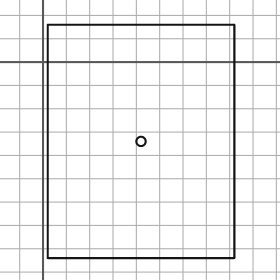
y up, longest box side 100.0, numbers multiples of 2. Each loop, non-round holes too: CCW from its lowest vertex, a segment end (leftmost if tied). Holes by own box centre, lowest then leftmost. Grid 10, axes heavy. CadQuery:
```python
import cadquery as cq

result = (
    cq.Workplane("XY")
    .moveTo(2.0, -84.0)
    .lineTo(82.0, -84.0)
    .lineTo(82.0, 16.0)
    .lineTo(2.0, 16.0)
    .close()
    .moveTo(42.0, -34.0)
    .circle(2.0)
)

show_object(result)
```